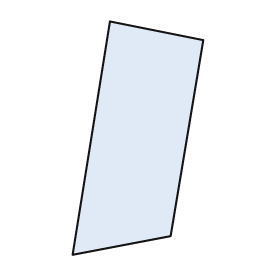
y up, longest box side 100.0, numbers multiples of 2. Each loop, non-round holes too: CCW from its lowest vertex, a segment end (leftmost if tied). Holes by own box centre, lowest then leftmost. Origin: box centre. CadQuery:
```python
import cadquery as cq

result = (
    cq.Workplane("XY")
    .moveTo(-28.0, -50.0)
    .lineTo(14.0, -42.0)
    .lineTo(28.0, 42.0)
    .lineTo(-12.0, 50.0)
    .close()
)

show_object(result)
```